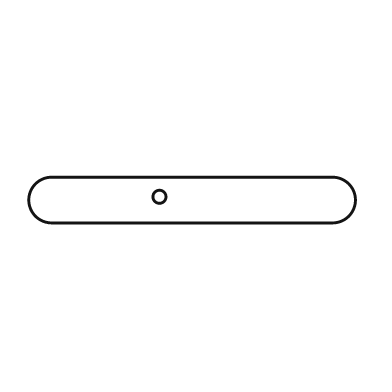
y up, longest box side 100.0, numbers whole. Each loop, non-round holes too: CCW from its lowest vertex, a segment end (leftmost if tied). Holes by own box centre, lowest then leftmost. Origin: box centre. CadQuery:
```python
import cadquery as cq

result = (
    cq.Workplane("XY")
    .moveTo(-43.0, -7.0)
    .lineTo(43.0, -7.0)
    .threePointArc((50.0, 0.0), (43.0, 7.0))
    .lineTo(-43.0, 7.0)
    .threePointArc((-50.0, 0.0), (-43.0, -7.0))
    .close()
    .moveTo(-10.0, 1.0)
    .circle(2.0)
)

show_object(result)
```